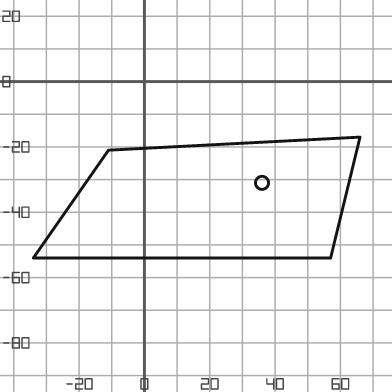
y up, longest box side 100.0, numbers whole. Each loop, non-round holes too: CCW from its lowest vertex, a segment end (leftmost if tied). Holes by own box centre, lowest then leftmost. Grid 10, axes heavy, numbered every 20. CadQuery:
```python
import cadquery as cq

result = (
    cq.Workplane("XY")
    .moveTo(-34.0, -54.0)
    .lineTo(57.0, -54.0)
    .lineTo(66.0, -17.0)
    .lineTo(-11.0, -21.0)
    .close()
    .moveTo(36.0, -31.0)
    .circle(2.0)
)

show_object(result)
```